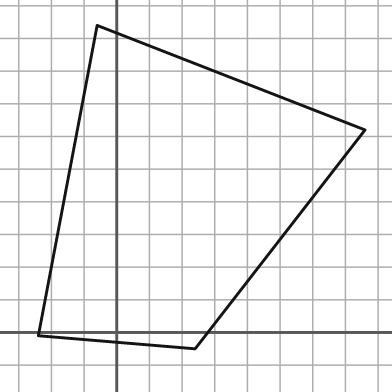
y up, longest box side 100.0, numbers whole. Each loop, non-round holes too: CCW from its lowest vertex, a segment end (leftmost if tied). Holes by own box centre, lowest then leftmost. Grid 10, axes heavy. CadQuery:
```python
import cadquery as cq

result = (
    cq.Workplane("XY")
    .moveTo(24.0, -5.0)
    .lineTo(76.0, 62.0)
    .lineTo(-6.0, 94.0)
    .lineTo(-24.0, -1.0)
    .close()
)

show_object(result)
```